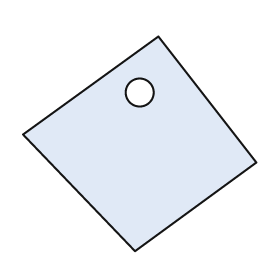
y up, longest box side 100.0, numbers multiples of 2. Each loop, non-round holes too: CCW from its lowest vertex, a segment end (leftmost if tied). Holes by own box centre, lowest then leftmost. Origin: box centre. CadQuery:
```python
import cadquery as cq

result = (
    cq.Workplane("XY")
    .moveTo(-2.0, -46.0)
    .lineTo(50.0, -8.0)
    .lineTo(8.0, 46.0)
    .lineTo(-50.0, 4.0)
    .close()
    .moveTo(0.0, 22.0)
    .circle(6.0)
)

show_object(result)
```